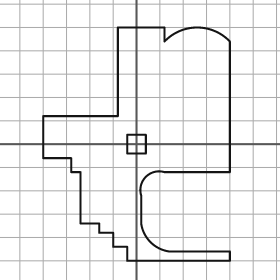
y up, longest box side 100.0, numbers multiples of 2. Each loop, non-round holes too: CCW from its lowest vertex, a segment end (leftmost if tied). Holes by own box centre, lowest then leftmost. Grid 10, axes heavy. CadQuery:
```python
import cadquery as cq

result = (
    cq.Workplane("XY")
    .moveTo(-4.0, -50.0)
    .lineTo(40.0, -50.0)
    .lineTo(40.0, -46.0)
    .lineTo(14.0, -46.0)
    .threePointArc((6.0, -42.0), (2.0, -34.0))
    .lineTo(2.0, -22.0)
    .threePointArc((4.0, -14.0), (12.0, -12.0))
    .lineTo(40.0, -12.0)
    .lineTo(40.0, 44.0)
    .threePointArc((26.0, 50.0), (12.0, 44.0))
    .lineTo(12.0, 50.0)
    .lineTo(-8.0, 50.0)
    .lineTo(-8.0, 12.0)
    .lineTo(-40.0, 12.0)
    .lineTo(-40.0, -6.0)
    .lineTo(-28.0, -6.0)
    .lineTo(-28.0, -12.0)
    .lineTo(-24.0, -12.0)
    .lineTo(-24.0, -34.0)
    .lineTo(-16.0, -34.0)
    .lineTo(-16.0, -38.0)
    .lineTo(-10.0, -38.0)
    .lineTo(-10.0, -44.0)
    .lineTo(-4.0, -44.0)
    .close()
    .moveTo(-4.0, -4.0)
    .lineTo(4.0, -4.0)
    .lineTo(4.0, 4.0)
    .lineTo(-4.0, 4.0)
    .close()
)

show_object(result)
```